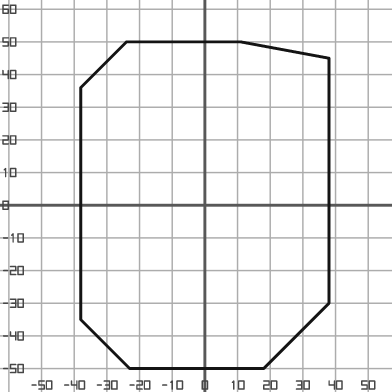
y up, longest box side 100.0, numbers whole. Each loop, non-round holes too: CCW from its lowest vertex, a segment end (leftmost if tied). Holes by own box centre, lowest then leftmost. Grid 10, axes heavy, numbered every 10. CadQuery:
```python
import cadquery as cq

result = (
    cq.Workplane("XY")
    .moveTo(-23.0, -50.0)
    .lineTo(18.0, -50.0)
    .lineTo(38.0, -30.0)
    .lineTo(38.0, 45.0)
    .lineTo(11.0, 50.0)
    .lineTo(-24.0, 50.0)
    .lineTo(-38.0, 36.0)
    .lineTo(-38.0, -35.0)
    .close()
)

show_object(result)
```